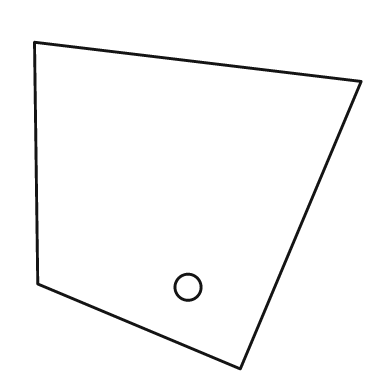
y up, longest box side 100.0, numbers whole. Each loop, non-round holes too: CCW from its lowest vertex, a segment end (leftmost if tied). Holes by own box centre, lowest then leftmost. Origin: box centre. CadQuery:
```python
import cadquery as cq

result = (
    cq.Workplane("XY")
    .moveTo(13.0, -50.0)
    .lineTo(50.0, 38.0)
    .lineTo(-50.0, 50.0)
    .lineTo(-49.0, -24.0)
    .close()
    .moveTo(-3.0, -25.0)
    .circle(4.0)
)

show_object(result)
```